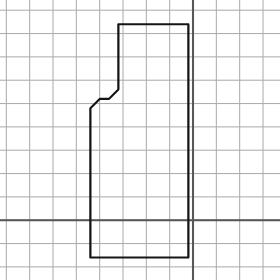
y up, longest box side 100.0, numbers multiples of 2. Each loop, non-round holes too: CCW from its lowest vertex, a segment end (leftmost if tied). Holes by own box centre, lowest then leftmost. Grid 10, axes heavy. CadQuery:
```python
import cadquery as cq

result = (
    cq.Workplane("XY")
    .moveTo(-44.0, -16.0)
    .lineTo(-2.0, -16.0)
    .lineTo(-2.0, 84.0)
    .lineTo(-32.0, 84.0)
    .lineTo(-32.0, 56.0)
    .lineTo(-36.0, 52.0)
    .lineTo(-40.0, 52.0)
    .lineTo(-44.0, 48.0)
    .close()
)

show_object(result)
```